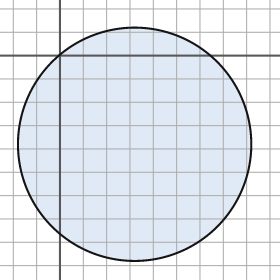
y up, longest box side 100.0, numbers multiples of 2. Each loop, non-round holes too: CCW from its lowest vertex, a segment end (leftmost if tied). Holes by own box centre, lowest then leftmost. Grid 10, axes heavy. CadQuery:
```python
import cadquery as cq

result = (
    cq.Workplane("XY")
    .moveTo(32.0, -38.0)
    .circle(50.0)
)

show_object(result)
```